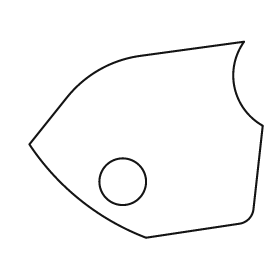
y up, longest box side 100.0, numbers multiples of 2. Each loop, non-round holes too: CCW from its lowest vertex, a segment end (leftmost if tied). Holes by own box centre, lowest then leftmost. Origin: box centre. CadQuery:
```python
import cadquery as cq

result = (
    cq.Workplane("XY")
    .moveTo(0.0, -42.0)
    .lineTo(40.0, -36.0)
    .threePointArc((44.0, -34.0), (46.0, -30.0))
    .lineTo(50.0, 6.0)
    .threePointArc((38.0, 22.0), (42.0, 42.0))
    .lineTo(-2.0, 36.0)
    .threePointArc((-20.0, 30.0), (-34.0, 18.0))
    .lineTo(-50.0, -2.0)
    .threePointArc((-28.0, -26.0), (0.0, -42.0))
    .close()
    .moveTo(-10.0, -18.0)
    .circle(10.0)
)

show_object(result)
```